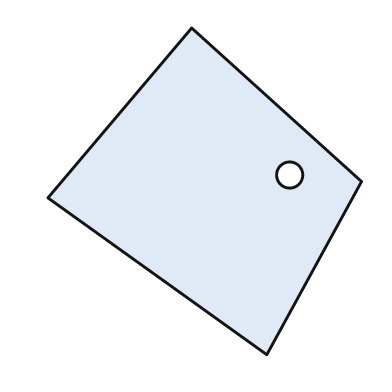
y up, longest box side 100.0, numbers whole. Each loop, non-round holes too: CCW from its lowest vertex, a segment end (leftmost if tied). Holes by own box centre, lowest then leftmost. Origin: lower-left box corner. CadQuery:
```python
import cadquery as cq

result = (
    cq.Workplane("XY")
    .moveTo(67.0, 0.0)
    .lineTo(96.0, 53.0)
    .lineTo(44.0, 100.0)
    .lineTo(0.0, 48.0)
    .close()
    .moveTo(74.0, 55.0)
    .circle(4.0)
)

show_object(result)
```